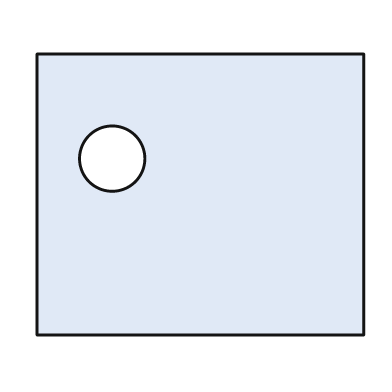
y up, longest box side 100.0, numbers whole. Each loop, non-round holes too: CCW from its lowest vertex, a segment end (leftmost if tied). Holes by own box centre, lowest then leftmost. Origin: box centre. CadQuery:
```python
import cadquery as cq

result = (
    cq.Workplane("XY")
    .moveTo(-50.0, -43.0)
    .lineTo(50.0, -43.0)
    .lineTo(50.0, 43.0)
    .lineTo(-50.0, 43.0)
    .close()
    .moveTo(-27.0, 11.0)
    .circle(10.0)
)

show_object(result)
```